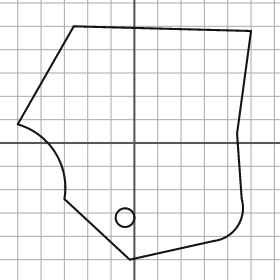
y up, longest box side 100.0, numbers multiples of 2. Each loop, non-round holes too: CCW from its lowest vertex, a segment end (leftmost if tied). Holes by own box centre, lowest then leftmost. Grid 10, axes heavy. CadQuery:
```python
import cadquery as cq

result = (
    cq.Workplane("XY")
    .moveTo(-2.0, -50.0)
    .lineTo(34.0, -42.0)
    .threePointArc((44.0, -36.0), (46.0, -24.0))
    .lineTo(44.0, 4.0)
    .lineTo(50.0, 48.0)
    .lineTo(-26.0, 50.0)
    .lineTo(-50.0, 8.0)
    .threePointArc((-34.0, -4.0), (-30.0, -24.0))
    .close()
    .moveTo(-4.0, -32.0)
    .circle(4.0)
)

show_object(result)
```